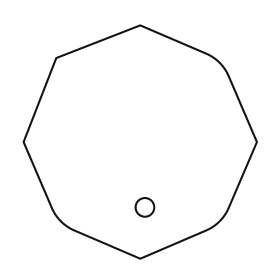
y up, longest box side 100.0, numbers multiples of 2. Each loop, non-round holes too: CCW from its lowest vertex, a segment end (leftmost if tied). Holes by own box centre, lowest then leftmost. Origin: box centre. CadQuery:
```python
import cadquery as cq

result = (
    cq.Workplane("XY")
    .moveTo(0.0, -50.0)
    .lineTo(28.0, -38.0)
    .threePointArc((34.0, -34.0), (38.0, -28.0))
    .lineTo(50.0, 0.0)
    .lineTo(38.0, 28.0)
    .threePointArc((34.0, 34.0), (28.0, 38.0))
    .lineTo(0.0, 50.0)
    .lineTo(-36.0, 36.0)
    .lineTo(-50.0, 0.0)
    .lineTo(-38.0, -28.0)
    .threePointArc((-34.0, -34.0), (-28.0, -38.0))
    .close()
    .moveTo(2.0, -28.0)
    .circle(4.0)
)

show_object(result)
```